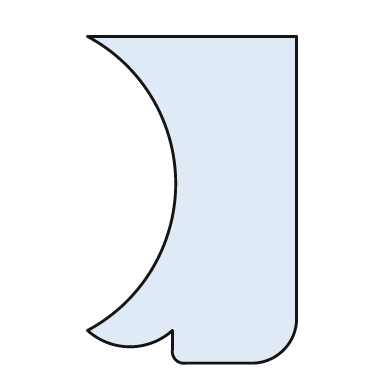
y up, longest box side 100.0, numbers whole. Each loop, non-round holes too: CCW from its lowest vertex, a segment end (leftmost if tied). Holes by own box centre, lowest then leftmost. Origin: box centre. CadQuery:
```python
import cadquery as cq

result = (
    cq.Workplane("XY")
    .moveTo(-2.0, -50.0)
    .lineTo(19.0, -50.0)
    .threePointArc((28.0, -46.0), (32.0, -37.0))
    .lineTo(32.0, 50.0)
    .lineTo(-32.0, 50.0)
    .threePointArc((-5.0, 5.0), (-32.0, -40.0))
    .threePointArc((-19.0, -45.0), (-6.0, -40.0))
    .lineTo(-6.0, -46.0)
    .threePointArc((-5.0, -49.0), (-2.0, -50.0))
    .close()
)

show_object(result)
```